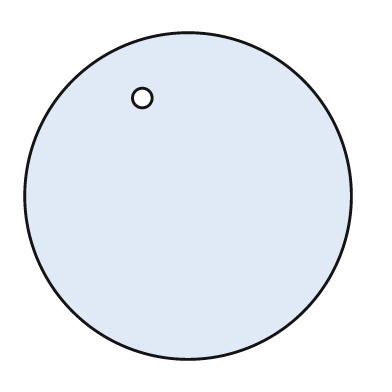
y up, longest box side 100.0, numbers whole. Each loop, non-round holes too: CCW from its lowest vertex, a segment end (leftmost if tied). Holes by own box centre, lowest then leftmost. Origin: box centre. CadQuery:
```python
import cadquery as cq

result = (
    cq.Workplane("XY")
    .moveTo(0.0, 0.0)
    .circle(50.0)
    .moveTo(-14.0, 30.0)
    .circle(3.0)
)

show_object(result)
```